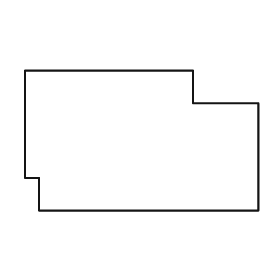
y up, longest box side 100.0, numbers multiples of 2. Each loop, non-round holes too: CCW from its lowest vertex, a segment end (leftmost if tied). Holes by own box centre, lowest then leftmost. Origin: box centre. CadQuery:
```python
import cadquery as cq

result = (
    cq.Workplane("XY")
    .moveTo(-44.0, -30.0)
    .lineTo(50.0, -30.0)
    .lineTo(50.0, 16.0)
    .lineTo(22.0, 16.0)
    .lineTo(22.0, 30.0)
    .lineTo(-50.0, 30.0)
    .lineTo(-50.0, -16.0)
    .lineTo(-44.0, -16.0)
    .close()
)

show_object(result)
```